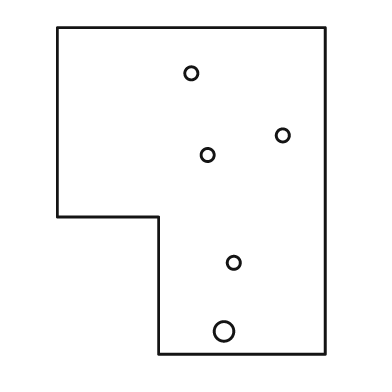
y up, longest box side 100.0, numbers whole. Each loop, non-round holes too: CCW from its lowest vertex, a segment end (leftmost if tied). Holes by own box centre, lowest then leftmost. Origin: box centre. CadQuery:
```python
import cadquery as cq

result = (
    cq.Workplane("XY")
    .moveTo(-10.0, -50.0)
    .lineTo(41.0, -50.0)
    .lineTo(41.0, 50.0)
    .lineTo(-41.0, 50.0)
    .lineTo(-41.0, -8.0)
    .lineTo(-10.0, -8.0)
    .close()
    .moveTo(10.0, -43.0)
    .circle(3.0)
    .moveTo(13.0, -22.0)
    .circle(2.0)
    .moveTo(5.0, 11.0)
    .circle(2.0)
    .moveTo(28.0, 17.0)
    .circle(2.0)
    .moveTo(0.0, 36.0)
    .circle(2.0)
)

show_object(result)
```